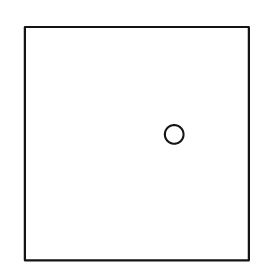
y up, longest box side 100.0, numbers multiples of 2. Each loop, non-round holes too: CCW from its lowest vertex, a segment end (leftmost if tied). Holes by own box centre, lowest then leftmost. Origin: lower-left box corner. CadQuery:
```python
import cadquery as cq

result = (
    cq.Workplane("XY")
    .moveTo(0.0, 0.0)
    .lineTo(96.0, 0.0)
    .lineTo(96.0, 100.0)
    .lineTo(0.0, 100.0)
    .close()
    .moveTo(64.0, 54.0)
    .circle(4.0)
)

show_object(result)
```